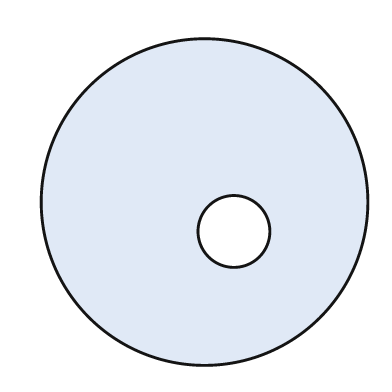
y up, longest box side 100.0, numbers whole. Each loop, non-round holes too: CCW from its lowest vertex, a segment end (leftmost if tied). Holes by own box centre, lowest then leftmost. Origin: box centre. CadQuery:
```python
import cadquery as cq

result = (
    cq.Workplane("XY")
    .moveTo(0.0, 0.0)
    .circle(50.0)
    .moveTo(9.0, -9.0)
    .circle(11.0)
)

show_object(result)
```